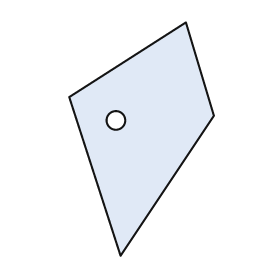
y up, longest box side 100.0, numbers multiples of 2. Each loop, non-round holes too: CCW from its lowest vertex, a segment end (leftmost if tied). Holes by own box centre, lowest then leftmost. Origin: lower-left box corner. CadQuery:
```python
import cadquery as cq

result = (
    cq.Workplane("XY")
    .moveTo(22.0, 0.0)
    .lineTo(62.0, 60.0)
    .lineTo(50.0, 100.0)
    .lineTo(0.0, 68.0)
    .close()
    .moveTo(20.0, 58.0)
    .circle(4.0)
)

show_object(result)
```